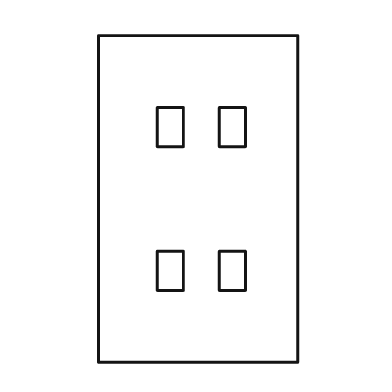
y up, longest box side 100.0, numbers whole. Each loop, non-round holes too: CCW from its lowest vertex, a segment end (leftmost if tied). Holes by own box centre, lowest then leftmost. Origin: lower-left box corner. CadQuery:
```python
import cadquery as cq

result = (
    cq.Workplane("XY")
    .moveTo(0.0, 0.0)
    .lineTo(61.0, 0.0)
    .lineTo(61.0, 100.0)
    .lineTo(0.0, 100.0)
    .close()
    .moveTo(18.0, 22.0)
    .lineTo(26.0, 22.0)
    .lineTo(26.0, 34.0)
    .lineTo(18.0, 34.0)
    .close()
    .moveTo(37.0, 22.0)
    .lineTo(45.0, 22.0)
    .lineTo(45.0, 34.0)
    .lineTo(37.0, 34.0)
    .close()
    .moveTo(18.0, 66.0)
    .lineTo(26.0, 66.0)
    .lineTo(26.0, 78.0)
    .lineTo(18.0, 78.0)
    .close()
    .moveTo(37.0, 66.0)
    .lineTo(45.0, 66.0)
    .lineTo(45.0, 78.0)
    .lineTo(37.0, 78.0)
    .close()
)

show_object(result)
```